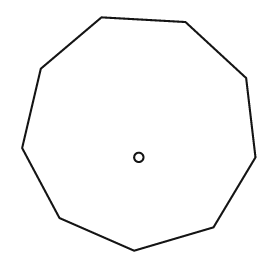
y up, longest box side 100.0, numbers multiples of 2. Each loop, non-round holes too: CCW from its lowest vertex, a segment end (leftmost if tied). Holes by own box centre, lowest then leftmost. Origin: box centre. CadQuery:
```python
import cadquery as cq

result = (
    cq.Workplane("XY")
    .moveTo(-2.0, -50.0)
    .lineTo(32.0, -40.0)
    .lineTo(50.0, -10.0)
    .lineTo(46.0, 24.0)
    .lineTo(20.0, 48.0)
    .lineTo(-16.0, 50.0)
    .lineTo(-42.0, 28.0)
    .lineTo(-50.0, -6.0)
    .lineTo(-34.0, -36.0)
    .close()
    .moveTo(0.0, -10.0)
    .circle(2.0)
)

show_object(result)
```